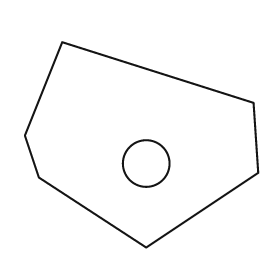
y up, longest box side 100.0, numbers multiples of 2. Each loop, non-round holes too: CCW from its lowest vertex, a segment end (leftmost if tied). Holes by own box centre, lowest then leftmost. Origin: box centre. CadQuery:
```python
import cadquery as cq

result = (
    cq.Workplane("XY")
    .moveTo(2.0, -44.0)
    .lineTo(50.0, -12.0)
    .lineTo(48.0, 18.0)
    .lineTo(-34.0, 44.0)
    .lineTo(-50.0, 4.0)
    .lineTo(-44.0, -14.0)
    .close()
    .moveTo(2.0, -8.0)
    .circle(10.0)
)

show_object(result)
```